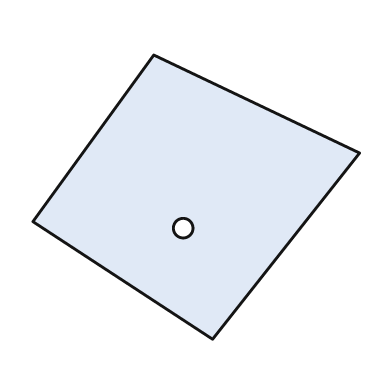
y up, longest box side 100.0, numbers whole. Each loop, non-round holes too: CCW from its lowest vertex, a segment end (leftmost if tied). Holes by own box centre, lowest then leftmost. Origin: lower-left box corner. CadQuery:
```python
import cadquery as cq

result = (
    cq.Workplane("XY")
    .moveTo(55.0, 0.0)
    .lineTo(100.0, 57.0)
    .lineTo(37.0, 87.0)
    .lineTo(0.0, 36.0)
    .close()
    .moveTo(46.0, 34.0)
    .circle(3.0)
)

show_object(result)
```